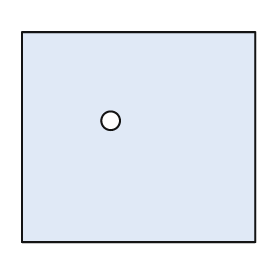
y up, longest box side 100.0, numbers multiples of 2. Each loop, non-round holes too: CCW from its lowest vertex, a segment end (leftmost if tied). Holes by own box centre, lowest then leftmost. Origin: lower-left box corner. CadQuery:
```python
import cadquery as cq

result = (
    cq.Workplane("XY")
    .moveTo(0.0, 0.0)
    .lineTo(100.0, 0.0)
    .lineTo(100.0, 90.0)
    .lineTo(0.0, 90.0)
    .close()
    .moveTo(38.0, 52.0)
    .circle(4.0)
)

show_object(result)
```